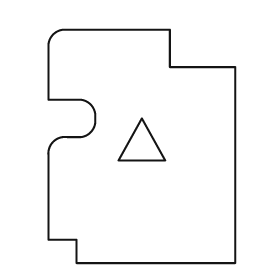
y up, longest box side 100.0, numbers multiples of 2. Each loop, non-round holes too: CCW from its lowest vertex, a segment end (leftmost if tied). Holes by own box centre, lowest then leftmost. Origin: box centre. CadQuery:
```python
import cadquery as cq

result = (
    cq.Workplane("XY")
    .moveTo(-28.0, -50.0)
    .lineTo(40.0, -50.0)
    .lineTo(40.0, 34.0)
    .lineTo(12.0, 34.0)
    .lineTo(12.0, 50.0)
    .lineTo(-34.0, 50.0)
    .threePointArc((-38.0, 48.0), (-40.0, 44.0))
    .lineTo(-40.0, 20.0)
    .lineTo(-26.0, 20.0)
    .threePointArc((-22.0, 18.0), (-20.0, 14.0))
    .lineTo(-20.0, 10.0)
    .threePointArc((-22.0, 6.0), (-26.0, 4.0))
    .lineTo(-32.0, 4.0)
    .threePointArc((-38.0, 2.0), (-40.0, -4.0))
    .lineTo(-40.0, -40.0)
    .lineTo(-28.0, -40.0)
    .close()
    .moveTo(-10.0, -6.0)
    .lineTo(10.0, -6.0)
    .lineTo(0.0, 12.0)
    .close()
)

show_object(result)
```